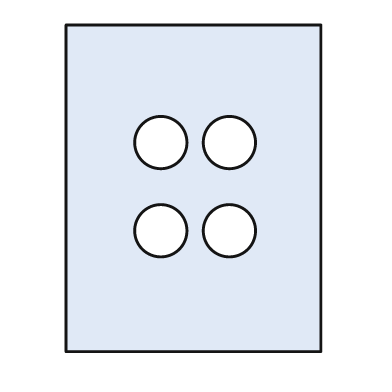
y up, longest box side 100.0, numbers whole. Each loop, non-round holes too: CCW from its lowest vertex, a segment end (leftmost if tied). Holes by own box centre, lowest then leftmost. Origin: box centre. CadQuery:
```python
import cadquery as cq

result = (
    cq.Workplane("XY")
    .moveTo(-39.0, -50.0)
    .lineTo(39.0, -50.0)
    .lineTo(39.0, 50.0)
    .lineTo(-39.0, 50.0)
    .close()
    .moveTo(-10.0, -13.0)
    .circle(8.0)
    .moveTo(11.0, -13.0)
    .circle(8.0)
    .moveTo(-10.0, 14.0)
    .circle(8.0)
    .moveTo(11.0, 14.0)
    .circle(8.0)
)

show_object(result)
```